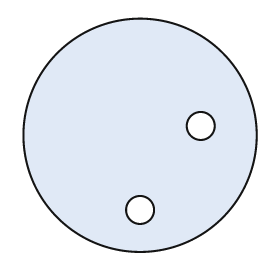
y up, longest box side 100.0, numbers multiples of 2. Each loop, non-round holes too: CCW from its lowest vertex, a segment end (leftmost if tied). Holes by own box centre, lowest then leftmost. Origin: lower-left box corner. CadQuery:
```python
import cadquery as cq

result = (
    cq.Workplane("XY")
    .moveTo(50.0, 50.0)
    .circle(50.0)
    .moveTo(50.0, 18.0)
    .circle(6.0)
    .moveTo(76.0, 54.0)
    .circle(6.0)
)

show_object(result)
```